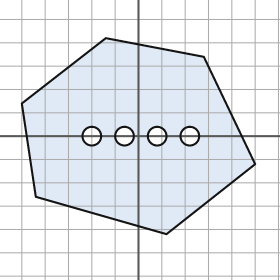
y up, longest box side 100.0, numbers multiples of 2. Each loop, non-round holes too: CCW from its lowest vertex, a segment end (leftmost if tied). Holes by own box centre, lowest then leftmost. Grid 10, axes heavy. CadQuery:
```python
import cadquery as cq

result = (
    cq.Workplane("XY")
    .moveTo(12.0, -42.0)
    .lineTo(50.0, -12.0)
    .lineTo(28.0, 34.0)
    .lineTo(-14.0, 42.0)
    .lineTo(-50.0, 14.0)
    .lineTo(-44.0, -26.0)
    .close()
    .moveTo(-20.0, 0.0)
    .circle(4.0)
    .moveTo(-6.0, 0.0)
    .circle(4.0)
    .moveTo(8.0, 0.0)
    .circle(4.0)
    .moveTo(22.0, 0.0)
    .circle(4.0)
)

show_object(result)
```